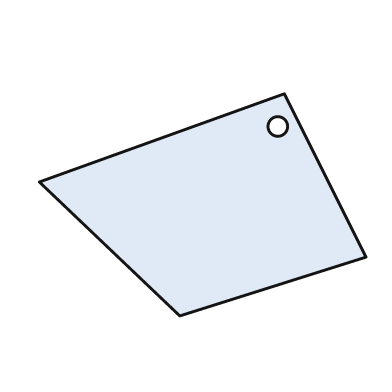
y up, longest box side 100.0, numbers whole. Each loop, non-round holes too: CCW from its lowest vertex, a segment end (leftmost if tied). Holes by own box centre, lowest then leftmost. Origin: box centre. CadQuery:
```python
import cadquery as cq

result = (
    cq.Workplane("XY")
    .moveTo(-7.0, -34.0)
    .lineTo(50.0, -16.0)
    .lineTo(25.0, 34.0)
    .lineTo(-50.0, 7.0)
    .close()
    .moveTo(23.0, 24.0)
    .circle(3.0)
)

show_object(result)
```